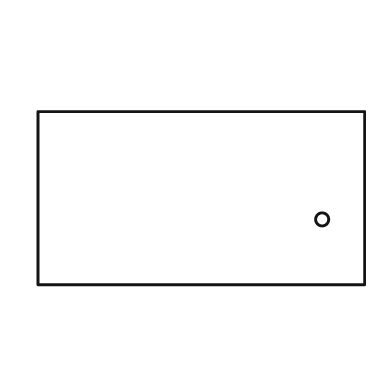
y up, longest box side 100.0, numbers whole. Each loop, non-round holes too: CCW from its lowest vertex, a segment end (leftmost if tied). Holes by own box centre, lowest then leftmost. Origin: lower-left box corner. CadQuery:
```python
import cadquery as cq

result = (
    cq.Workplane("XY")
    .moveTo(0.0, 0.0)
    .lineTo(100.0, 0.0)
    .lineTo(100.0, 53.0)
    .lineTo(0.0, 53.0)
    .close()
    .moveTo(87.0, 20.0)
    .circle(2.0)
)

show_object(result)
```